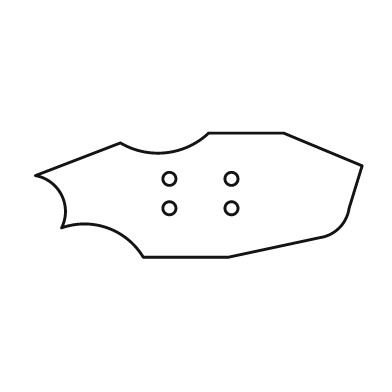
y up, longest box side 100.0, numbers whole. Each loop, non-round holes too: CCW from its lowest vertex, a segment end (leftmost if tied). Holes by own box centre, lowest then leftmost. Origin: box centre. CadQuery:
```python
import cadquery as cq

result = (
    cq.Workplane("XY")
    .moveTo(-17.0, -19.0)
    .lineTo(9.0, -19.0)
    .lineTo(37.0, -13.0)
    .threePointArc((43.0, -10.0), (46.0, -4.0))
    .lineTo(50.0, 9.0)
    .lineTo(26.0, 19.0)
    .lineTo(3.0, 19.0)
    .threePointArc((-10.0, 13.0), (-24.0, 16.0))
    .lineTo(-50.0, 6.0)
    .threePointArc((-42.0, 0.0), (-42.0, -10.0))
    .threePointArc((-28.0, -10.0), (-17.0, -19.0))
    .close()
    .moveTo(-9.0, -4.0)
    .circle(2.0)
    .moveTo(10.0, -4.0)
    .circle(2.0)
    .moveTo(-9.0, 5.0)
    .circle(2.0)
    .moveTo(10.0, 5.0)
    .circle(2.0)
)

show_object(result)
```